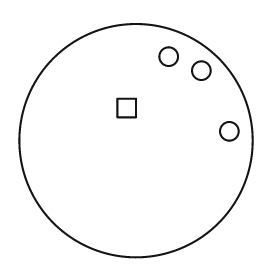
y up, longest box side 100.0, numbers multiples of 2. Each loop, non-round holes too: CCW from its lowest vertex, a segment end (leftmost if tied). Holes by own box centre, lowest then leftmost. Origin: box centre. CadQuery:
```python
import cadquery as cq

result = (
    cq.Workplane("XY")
    .moveTo(0.0, 0.0)
    .circle(50.0)
    .moveTo(40.0, 4.0)
    .circle(4.0)
    .moveTo(-8.0, 10.0)
    .lineTo(0.0, 10.0)
    .lineTo(0.0, 18.0)
    .lineTo(-8.0, 18.0)
    .close()
    .moveTo(28.0, 30.0)
    .circle(4.0)
    .moveTo(14.0, 36.0)
    .circle(4.0)
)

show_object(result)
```